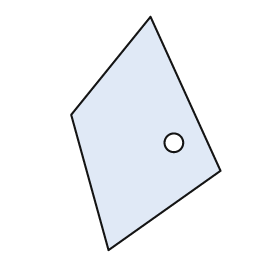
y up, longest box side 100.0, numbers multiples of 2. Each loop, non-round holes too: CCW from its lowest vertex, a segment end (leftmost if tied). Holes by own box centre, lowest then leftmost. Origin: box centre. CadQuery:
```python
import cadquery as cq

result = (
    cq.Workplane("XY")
    .moveTo(-16.0, -50.0)
    .lineTo(32.0, -16.0)
    .lineTo(2.0, 50.0)
    .lineTo(-32.0, 8.0)
    .close()
    .moveTo(12.0, -4.0)
    .circle(4.0)
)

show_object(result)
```